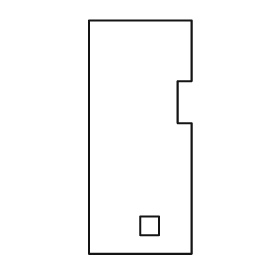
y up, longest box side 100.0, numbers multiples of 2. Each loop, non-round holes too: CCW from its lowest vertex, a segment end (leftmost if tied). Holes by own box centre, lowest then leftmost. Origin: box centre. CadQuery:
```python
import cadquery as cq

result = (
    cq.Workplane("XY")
    .moveTo(-22.0, -50.0)
    .lineTo(22.0, -50.0)
    .lineTo(22.0, 6.0)
    .lineTo(16.0, 6.0)
    .lineTo(16.0, 24.0)
    .lineTo(22.0, 24.0)
    .lineTo(22.0, 50.0)
    .lineTo(-22.0, 50.0)
    .close()
    .moveTo(0.0, -42.0)
    .lineTo(8.0, -42.0)
    .lineTo(8.0, -34.0)
    .lineTo(0.0, -34.0)
    .close()
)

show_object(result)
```